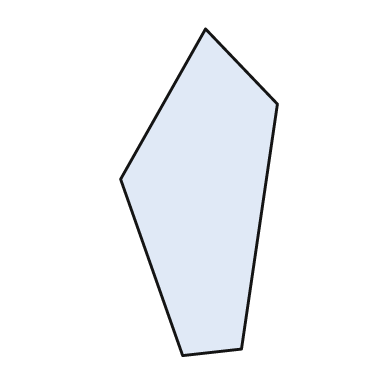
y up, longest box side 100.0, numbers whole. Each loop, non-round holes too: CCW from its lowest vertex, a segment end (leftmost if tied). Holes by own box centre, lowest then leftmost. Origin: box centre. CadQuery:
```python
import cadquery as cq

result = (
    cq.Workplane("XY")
    .moveTo(-5.0, -50.0)
    .lineTo(13.0, -48.0)
    .lineTo(24.0, 27.0)
    .lineTo(2.0, 50.0)
    .lineTo(-24.0, 4.0)
    .close()
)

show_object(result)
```